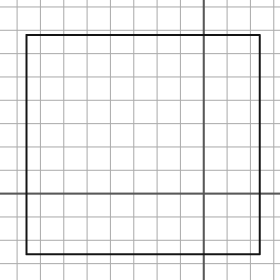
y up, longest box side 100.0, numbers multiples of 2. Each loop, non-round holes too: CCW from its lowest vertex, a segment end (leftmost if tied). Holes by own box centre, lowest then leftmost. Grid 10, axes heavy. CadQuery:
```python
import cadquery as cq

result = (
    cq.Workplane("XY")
    .moveTo(-76.0, -26.0)
    .lineTo(24.0, -26.0)
    .lineTo(24.0, 68.0)
    .lineTo(-76.0, 68.0)
    .close()
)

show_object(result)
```